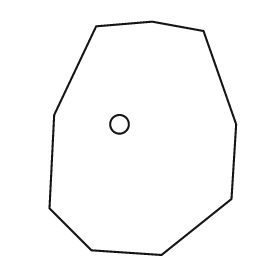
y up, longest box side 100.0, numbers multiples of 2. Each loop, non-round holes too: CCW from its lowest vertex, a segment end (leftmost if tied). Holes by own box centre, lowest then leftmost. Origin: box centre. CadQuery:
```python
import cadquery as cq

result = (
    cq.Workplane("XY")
    .moveTo(8.0, -50.0)
    .lineTo(38.0, -26.0)
    .lineTo(40.0, 6.0)
    .lineTo(26.0, 46.0)
    .lineTo(4.0, 50.0)
    .lineTo(-20.0, 48.0)
    .lineTo(-38.0, 10.0)
    .lineTo(-40.0, -30.0)
    .lineTo(-22.0, -48.0)
    .close()
    .moveTo(-10.0, 6.0)
    .circle(4.0)
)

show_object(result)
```